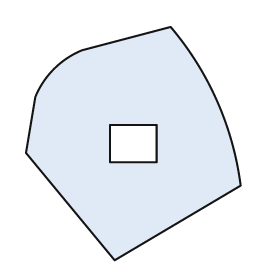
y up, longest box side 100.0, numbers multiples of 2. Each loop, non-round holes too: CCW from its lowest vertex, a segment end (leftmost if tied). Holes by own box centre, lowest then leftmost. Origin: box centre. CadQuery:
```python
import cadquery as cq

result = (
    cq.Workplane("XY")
    .moveTo(-8.0, -50.0)
    .lineTo(46.0, -18.0)
    .threePointArc((36.0, 18.0), (16.0, 50.0))
    .lineTo(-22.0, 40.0)
    .threePointArc((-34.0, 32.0), (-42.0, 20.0))
    .lineTo(-46.0, -4.0)
    .close()
    .moveTo(-10.0, -8.0)
    .lineTo(10.0, -8.0)
    .lineTo(10.0, 8.0)
    .lineTo(-10.0, 8.0)
    .close()
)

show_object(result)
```